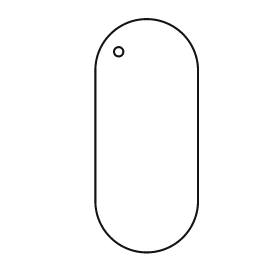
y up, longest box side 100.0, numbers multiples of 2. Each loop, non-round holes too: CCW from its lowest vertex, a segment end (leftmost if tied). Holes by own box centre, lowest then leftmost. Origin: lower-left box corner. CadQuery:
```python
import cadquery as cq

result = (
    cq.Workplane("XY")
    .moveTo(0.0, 22.0)
    .threePointArc((22.0, 0.0), (44.0, 22.0))
    .lineTo(44.0, 78.0)
    .threePointArc((22.0, 100.0), (0.0, 78.0))
    .close()
    .moveTo(10.0, 86.0)
    .circle(2.0)
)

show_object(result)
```